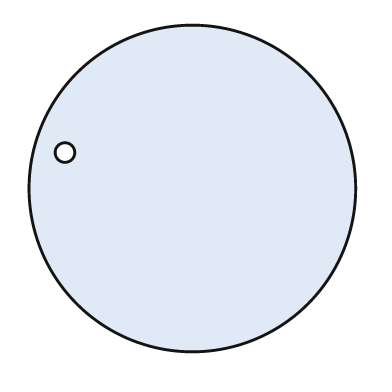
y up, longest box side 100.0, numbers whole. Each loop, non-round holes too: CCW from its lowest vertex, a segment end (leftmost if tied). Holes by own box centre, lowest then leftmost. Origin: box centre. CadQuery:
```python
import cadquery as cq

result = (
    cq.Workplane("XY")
    .moveTo(0.0, 0.0)
    .circle(50.0)
    .moveTo(-39.0, 11.0)
    .circle(3.0)
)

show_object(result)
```